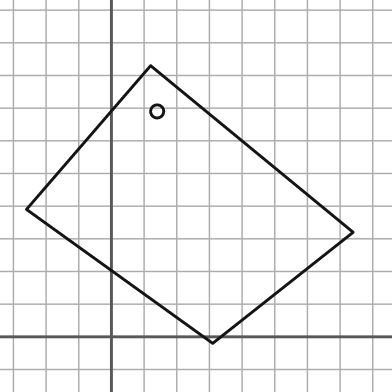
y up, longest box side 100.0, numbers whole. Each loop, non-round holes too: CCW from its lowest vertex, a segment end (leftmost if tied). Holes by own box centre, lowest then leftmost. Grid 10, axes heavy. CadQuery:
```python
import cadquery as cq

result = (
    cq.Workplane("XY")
    .moveTo(31.0, -2.0)
    .lineTo(74.0, 32.0)
    .lineTo(12.0, 83.0)
    .lineTo(-26.0, 39.0)
    .close()
    .moveTo(14.0, 69.0)
    .circle(2.0)
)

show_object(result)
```